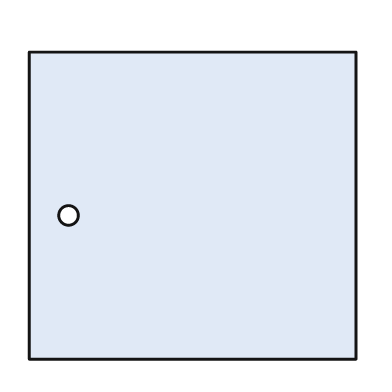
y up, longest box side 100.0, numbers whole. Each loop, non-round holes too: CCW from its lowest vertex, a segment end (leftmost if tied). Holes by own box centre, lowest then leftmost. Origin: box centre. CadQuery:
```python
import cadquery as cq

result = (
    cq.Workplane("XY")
    .moveTo(-50.0, -47.0)
    .lineTo(50.0, -47.0)
    .lineTo(50.0, 47.0)
    .lineTo(-50.0, 47.0)
    .close()
    .moveTo(-38.0, -3.0)
    .circle(3.0)
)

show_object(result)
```